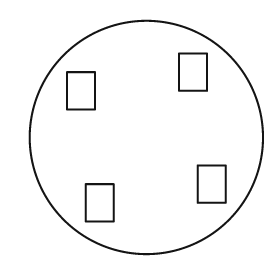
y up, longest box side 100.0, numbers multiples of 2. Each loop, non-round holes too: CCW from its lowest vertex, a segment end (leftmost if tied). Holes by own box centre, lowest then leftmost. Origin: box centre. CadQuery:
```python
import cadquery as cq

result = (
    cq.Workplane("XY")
    .moveTo(0.0, 0.0)
    .circle(50.0)
    .moveTo(-26.0, -36.0)
    .lineTo(-14.0, -36.0)
    .lineTo(-14.0, -20.0)
    .lineTo(-26.0, -20.0)
    .close()
    .moveTo(22.0, -28.0)
    .lineTo(34.0, -28.0)
    .lineTo(34.0, -12.0)
    .lineTo(22.0, -12.0)
    .close()
    .moveTo(-34.0, 12.0)
    .lineTo(-22.0, 12.0)
    .lineTo(-22.0, 28.0)
    .lineTo(-34.0, 28.0)
    .close()
    .moveTo(14.0, 20.0)
    .lineTo(26.0, 20.0)
    .lineTo(26.0, 36.0)
    .lineTo(14.0, 36.0)
    .close()
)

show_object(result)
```